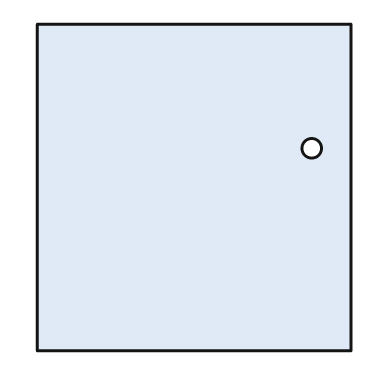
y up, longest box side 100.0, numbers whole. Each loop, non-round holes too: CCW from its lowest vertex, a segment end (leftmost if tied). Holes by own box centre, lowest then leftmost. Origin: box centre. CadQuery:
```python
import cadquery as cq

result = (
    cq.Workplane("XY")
    .moveTo(-48.0, -50.0)
    .lineTo(48.0, -50.0)
    .lineTo(48.0, 50.0)
    .lineTo(-48.0, 50.0)
    .close()
    .moveTo(36.0, 12.0)
    .circle(3.0)
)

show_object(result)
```